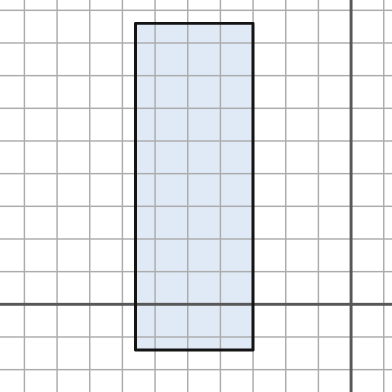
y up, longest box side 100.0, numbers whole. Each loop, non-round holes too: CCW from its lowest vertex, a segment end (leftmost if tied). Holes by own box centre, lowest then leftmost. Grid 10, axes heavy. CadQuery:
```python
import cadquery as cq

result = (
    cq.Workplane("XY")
    .moveTo(-66.0, -14.0)
    .lineTo(-30.0, -14.0)
    .lineTo(-30.0, 86.0)
    .lineTo(-66.0, 86.0)
    .close()
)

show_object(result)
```